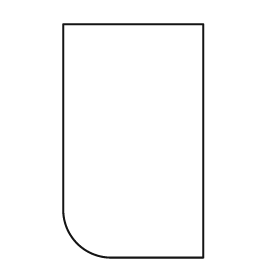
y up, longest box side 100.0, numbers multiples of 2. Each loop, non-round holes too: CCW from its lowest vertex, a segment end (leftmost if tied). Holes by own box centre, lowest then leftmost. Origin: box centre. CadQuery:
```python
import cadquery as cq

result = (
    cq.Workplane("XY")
    .moveTo(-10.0, -50.0)
    .lineTo(30.0, -50.0)
    .lineTo(30.0, 50.0)
    .lineTo(-30.0, 50.0)
    .lineTo(-30.0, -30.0)
    .threePointArc((-24.0, -44.0), (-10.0, -50.0))
    .close()
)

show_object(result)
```